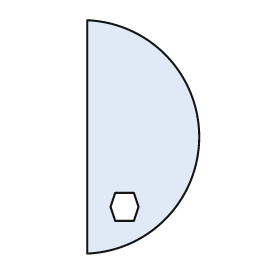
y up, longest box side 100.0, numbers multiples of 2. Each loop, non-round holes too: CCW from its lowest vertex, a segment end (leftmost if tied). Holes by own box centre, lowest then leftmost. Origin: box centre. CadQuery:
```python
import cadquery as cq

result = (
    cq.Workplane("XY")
    .moveTo(-24.0, -50.0)
    .threePointArc((24.0, 0.0), (-24.0, 50.0))
    .close()
    .moveTo(-12.0, -36.0)
    .lineTo(-4.0, -36.0)
    .lineTo(-2.0, -30.0)
    .lineTo(-4.0, -24.0)
    .lineTo(-12.0, -24.0)
    .lineTo(-14.0, -30.0)
    .close()
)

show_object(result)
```